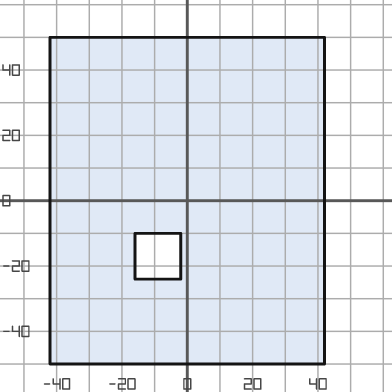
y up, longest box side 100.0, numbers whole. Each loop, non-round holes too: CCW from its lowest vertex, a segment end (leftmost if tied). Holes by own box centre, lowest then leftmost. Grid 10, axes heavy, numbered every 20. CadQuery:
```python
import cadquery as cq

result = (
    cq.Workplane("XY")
    .moveTo(-42.0, -50.0)
    .lineTo(42.0, -50.0)
    .lineTo(42.0, 50.0)
    .lineTo(-42.0, 50.0)
    .close()
    .moveTo(-16.0, -24.0)
    .lineTo(-2.0, -24.0)
    .lineTo(-2.0, -10.0)
    .lineTo(-16.0, -10.0)
    .close()
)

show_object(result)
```